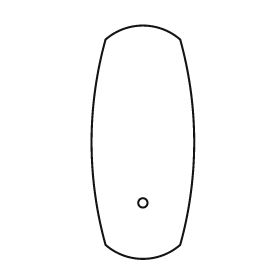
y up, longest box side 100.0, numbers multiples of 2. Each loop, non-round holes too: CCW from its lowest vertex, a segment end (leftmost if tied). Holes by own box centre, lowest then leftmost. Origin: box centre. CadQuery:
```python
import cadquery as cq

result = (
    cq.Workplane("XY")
    .moveTo(-16.0, -44.0)
    .threePointArc((0.0, -50.0), (16.0, -44.0))
    .threePointArc((22.0, 0.0), (16.0, 44.0))
    .threePointArc((0.0, 50.0), (-16.0, 44.0))
    .threePointArc((-22.0, 0.0), (-16.0, -44.0))
    .close()
    .moveTo(0.0, -26.0)
    .circle(2.0)
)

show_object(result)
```